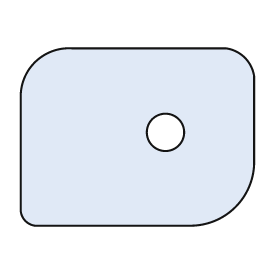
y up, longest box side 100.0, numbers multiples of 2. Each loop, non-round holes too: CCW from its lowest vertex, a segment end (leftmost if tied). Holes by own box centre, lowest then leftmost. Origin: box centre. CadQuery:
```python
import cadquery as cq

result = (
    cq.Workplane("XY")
    .moveTo(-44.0, -38.0)
    .lineTo(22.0, -38.0)
    .threePointArc((42.0, -30.0), (50.0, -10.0))
    .lineTo(50.0, 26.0)
    .threePointArc((46.0, 34.0), (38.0, 38.0))
    .lineTo(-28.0, 38.0)
    .threePointArc((-44.0, 32.0), (-50.0, 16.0))
    .lineTo(-50.0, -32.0)
    .threePointArc((-48.0, -36.0), (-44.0, -38.0))
    .close()
    .moveTo(12.0, 2.0)
    .circle(8.0)
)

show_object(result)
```